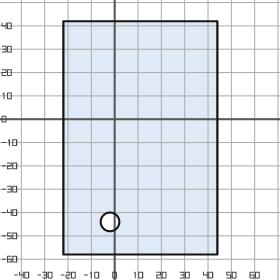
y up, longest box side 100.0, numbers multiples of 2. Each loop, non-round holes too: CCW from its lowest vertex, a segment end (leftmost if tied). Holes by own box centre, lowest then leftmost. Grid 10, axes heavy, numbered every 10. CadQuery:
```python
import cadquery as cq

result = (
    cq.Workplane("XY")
    .moveTo(-22.0, -58.0)
    .lineTo(44.0, -58.0)
    .lineTo(44.0, 42.0)
    .lineTo(-22.0, 42.0)
    .close()
    .moveTo(-2.0, -44.0)
    .circle(4.0)
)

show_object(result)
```